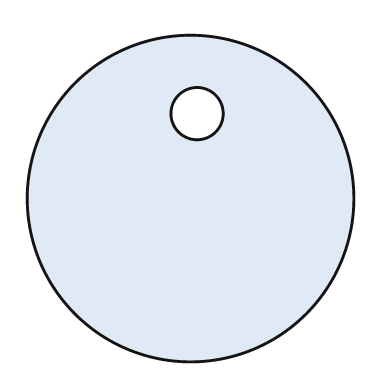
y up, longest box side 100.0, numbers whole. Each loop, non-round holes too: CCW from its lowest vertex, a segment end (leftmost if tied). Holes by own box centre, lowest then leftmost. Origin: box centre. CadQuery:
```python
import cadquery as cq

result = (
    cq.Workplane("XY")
    .moveTo(0.0, 0.0)
    .circle(50.0)
    .moveTo(2.0, 26.0)
    .circle(8.0)
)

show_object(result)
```